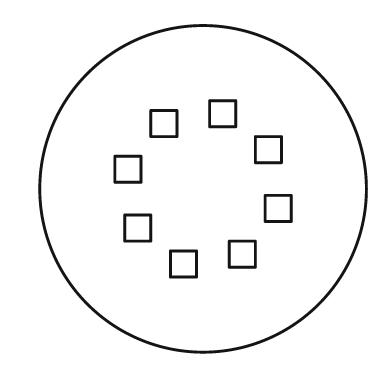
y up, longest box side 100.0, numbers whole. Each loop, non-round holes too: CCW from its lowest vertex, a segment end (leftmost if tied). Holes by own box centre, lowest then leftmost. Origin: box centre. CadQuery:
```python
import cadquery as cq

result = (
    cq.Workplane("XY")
    .moveTo(0.0, 0.0)
    .circle(50.0)
    .moveTo(-10.0, -27.0)
    .lineTo(-2.0, -27.0)
    .lineTo(-2.0, -19.0)
    .lineTo(-10.0, -19.0)
    .close()
    .moveTo(8.0, -24.0)
    .lineTo(16.0, -24.0)
    .lineTo(16.0, -16.0)
    .lineTo(8.0, -16.0)
    .close()
    .moveTo(-24.0, -16.0)
    .lineTo(-16.0, -16.0)
    .lineTo(-16.0, -8.0)
    .lineTo(-24.0, -8.0)
    .close()
    .moveTo(19.0, -10.0)
    .lineTo(27.0, -10.0)
    .lineTo(27.0, -2.0)
    .lineTo(19.0, -2.0)
    .close()
    .moveTo(-27.0, 2.0)
    .lineTo(-19.0, 2.0)
    .lineTo(-19.0, 10.0)
    .lineTo(-27.0, 10.0)
    .close()
    .moveTo(16.0, 8.0)
    .lineTo(24.0, 8.0)
    .lineTo(24.0, 16.0)
    .lineTo(16.0, 16.0)
    .close()
    .moveTo(-16.0, 16.0)
    .lineTo(-8.0, 16.0)
    .lineTo(-8.0, 24.0)
    .lineTo(-16.0, 24.0)
    .close()
    .moveTo(2.0, 19.0)
    .lineTo(10.0, 19.0)
    .lineTo(10.0, 27.0)
    .lineTo(2.0, 27.0)
    .close()
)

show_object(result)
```